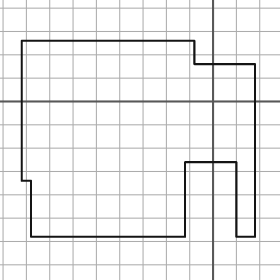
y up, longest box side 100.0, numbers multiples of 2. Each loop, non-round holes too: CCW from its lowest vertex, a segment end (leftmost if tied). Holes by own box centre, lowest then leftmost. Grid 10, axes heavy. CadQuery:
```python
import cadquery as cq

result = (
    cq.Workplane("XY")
    .moveTo(-78.0, -58.0)
    .lineTo(-12.0, -58.0)
    .lineTo(-12.0, -26.0)
    .lineTo(10.0, -26.0)
    .lineTo(10.0, -58.0)
    .lineTo(18.0, -58.0)
    .lineTo(18.0, 16.0)
    .lineTo(-8.0, 16.0)
    .lineTo(-8.0, 26.0)
    .lineTo(-82.0, 26.0)
    .lineTo(-82.0, -34.0)
    .lineTo(-78.0, -34.0)
    .close()
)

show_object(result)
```